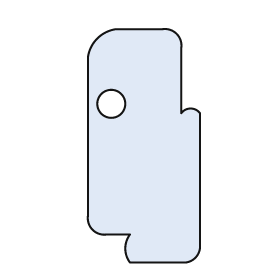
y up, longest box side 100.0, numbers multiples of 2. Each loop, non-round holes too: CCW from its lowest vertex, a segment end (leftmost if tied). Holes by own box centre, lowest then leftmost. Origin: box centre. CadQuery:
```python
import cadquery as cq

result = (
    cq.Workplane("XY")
    .moveTo(-6.0, -50.0)
    .lineTo(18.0, -50.0)
    .threePointArc((22.0, -48.0), (24.0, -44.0))
    .lineTo(24.0, 14.0)
    .threePointArc((20.0, 16.0), (16.0, 14.0))
    .lineTo(16.0, 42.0)
    .threePointArc((14.0, 48.0), (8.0, 50.0))
    .lineTo(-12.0, 50.0)
    .threePointArc((-20.0, 46.0), (-24.0, 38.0))
    .lineTo(-24.0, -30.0)
    .threePointArc((-22.0, -36.0), (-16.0, -38.0))
    .lineTo(-6.0, -38.0)
    .threePointArc((-8.0, -44.0), (-6.0, -50.0))
    .close()
    .moveTo(-14.0, 18.0)
    .circle(6.0)
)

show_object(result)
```